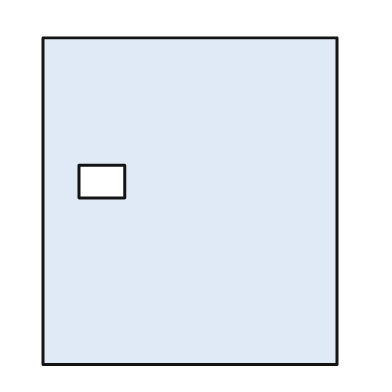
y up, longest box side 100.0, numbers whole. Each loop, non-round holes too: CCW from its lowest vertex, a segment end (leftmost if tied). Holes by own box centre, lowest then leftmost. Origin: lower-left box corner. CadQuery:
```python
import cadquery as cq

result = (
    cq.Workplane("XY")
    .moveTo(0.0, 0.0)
    .lineTo(90.0, 0.0)
    .lineTo(90.0, 100.0)
    .lineTo(0.0, 100.0)
    .close()
    .moveTo(11.0, 51.0)
    .lineTo(25.0, 51.0)
    .lineTo(25.0, 61.0)
    .lineTo(11.0, 61.0)
    .close()
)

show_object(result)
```